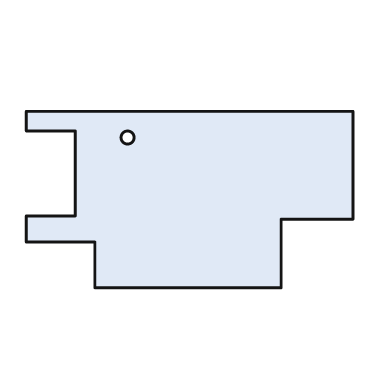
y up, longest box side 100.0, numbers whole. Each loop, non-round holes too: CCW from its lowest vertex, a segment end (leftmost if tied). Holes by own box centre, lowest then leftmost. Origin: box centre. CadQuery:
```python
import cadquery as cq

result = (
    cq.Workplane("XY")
    .moveTo(-29.0, -27.0)
    .lineTo(28.0, -27.0)
    .lineTo(28.0, -6.0)
    .lineTo(50.0, -6.0)
    .lineTo(50.0, 27.0)
    .lineTo(-50.0, 27.0)
    .lineTo(-50.0, 21.0)
    .lineTo(-35.0, 21.0)
    .lineTo(-35.0, -5.0)
    .lineTo(-50.0, -5.0)
    .lineTo(-50.0, -13.0)
    .lineTo(-29.0, -13.0)
    .close()
    .moveTo(-19.0, 19.0)
    .circle(2.0)
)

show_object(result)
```